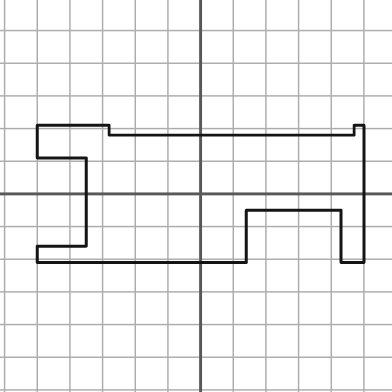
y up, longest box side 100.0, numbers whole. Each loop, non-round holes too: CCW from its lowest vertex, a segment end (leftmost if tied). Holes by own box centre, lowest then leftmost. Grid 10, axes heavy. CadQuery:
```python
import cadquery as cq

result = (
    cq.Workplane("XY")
    .moveTo(-50.0, -21.0)
    .lineTo(14.0, -21.0)
    .lineTo(14.0, -5.0)
    .lineTo(43.0, -5.0)
    .lineTo(43.0, -21.0)
    .lineTo(50.0, -21.0)
    .lineTo(50.0, 21.0)
    .lineTo(47.0, 21.0)
    .lineTo(47.0, 18.0)
    .lineTo(-28.0, 18.0)
    .lineTo(-28.0, 21.0)
    .lineTo(-50.0, 21.0)
    .lineTo(-50.0, 11.0)
    .lineTo(-35.0, 11.0)
    .lineTo(-35.0, -16.0)
    .lineTo(-50.0, -16.0)
    .close()
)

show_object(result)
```